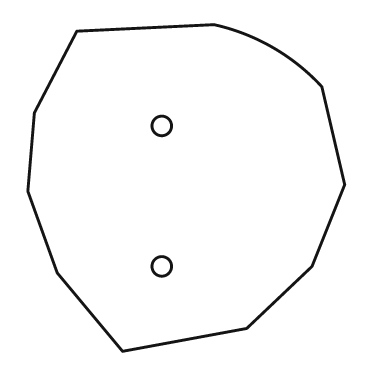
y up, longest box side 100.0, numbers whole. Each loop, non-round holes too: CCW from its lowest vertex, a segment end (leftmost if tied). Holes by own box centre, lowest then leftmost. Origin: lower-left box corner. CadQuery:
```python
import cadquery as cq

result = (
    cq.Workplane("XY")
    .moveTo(29.0, 0.0)
    .lineTo(67.0, 7.0)
    .lineTo(87.0, 26.0)
    .lineTo(97.0, 51.0)
    .lineTo(90.0, 81.0)
    .threePointArc((75.0, 93.0), (57.0, 100.0))
    .lineTo(15.0, 98.0)
    .lineTo(2.0, 73.0)
    .lineTo(0.0, 49.0)
    .lineTo(9.0, 24.0)
    .close()
    .moveTo(41.0, 26.0)
    .circle(3.0)
    .moveTo(41.0, 69.0)
    .circle(3.0)
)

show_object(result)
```